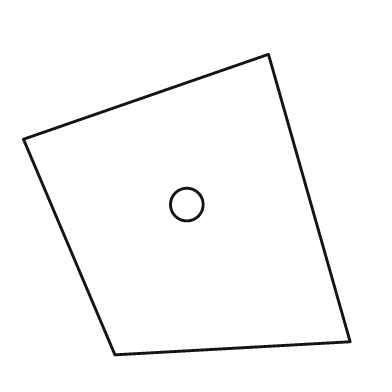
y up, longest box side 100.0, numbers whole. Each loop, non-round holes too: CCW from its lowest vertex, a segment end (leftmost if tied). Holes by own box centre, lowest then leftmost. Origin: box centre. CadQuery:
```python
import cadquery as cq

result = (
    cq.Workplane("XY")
    .moveTo(-22.0, -46.0)
    .lineTo(50.0, -42.0)
    .lineTo(25.0, 46.0)
    .lineTo(-50.0, 20.0)
    .close()
    .moveTo(0.0, 0.0)
    .circle(5.0)
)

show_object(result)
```